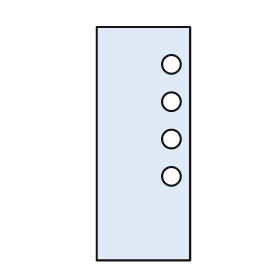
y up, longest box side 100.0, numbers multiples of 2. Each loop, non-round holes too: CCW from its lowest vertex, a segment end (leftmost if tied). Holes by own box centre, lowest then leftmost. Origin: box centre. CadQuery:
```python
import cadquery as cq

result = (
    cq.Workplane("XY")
    .moveTo(-20.0, -50.0)
    .lineTo(20.0, -50.0)
    .lineTo(20.0, 50.0)
    .lineTo(-20.0, 50.0)
    .close()
    .moveTo(12.0, -14.0)
    .circle(4.0)
    .moveTo(12.0, 2.0)
    .circle(4.0)
    .moveTo(12.0, 18.0)
    .circle(4.0)
    .moveTo(12.0, 34.0)
    .circle(4.0)
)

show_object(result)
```